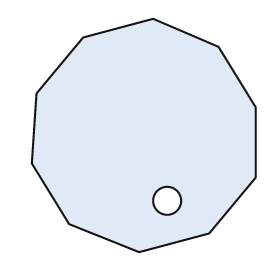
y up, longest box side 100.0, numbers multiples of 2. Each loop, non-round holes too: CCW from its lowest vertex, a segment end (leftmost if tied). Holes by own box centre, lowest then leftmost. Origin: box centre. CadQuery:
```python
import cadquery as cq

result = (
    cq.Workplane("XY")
    .moveTo(-2.0, -50.0)
    .lineTo(28.0, -42.0)
    .lineTo(48.0, -18.0)
    .lineTo(48.0, 12.0)
    .lineTo(32.0, 38.0)
    .lineTo(4.0, 50.0)
    .lineTo(-26.0, 42.0)
    .lineTo(-46.0, 18.0)
    .lineTo(-48.0, -12.0)
    .lineTo(-32.0, -38.0)
    .close()
    .moveTo(10.0, -28.0)
    .circle(6.0)
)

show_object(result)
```